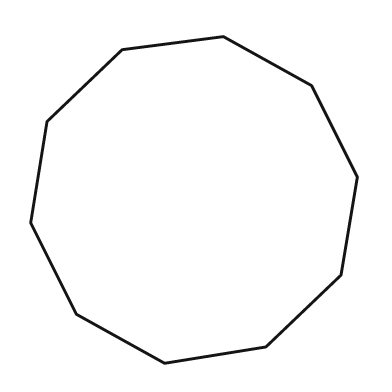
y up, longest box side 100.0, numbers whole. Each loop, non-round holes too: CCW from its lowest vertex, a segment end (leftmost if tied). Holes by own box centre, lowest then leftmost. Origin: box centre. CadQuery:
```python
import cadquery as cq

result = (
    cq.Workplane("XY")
    .moveTo(-9.0, -50.0)
    .lineTo(22.0, -45.0)
    .lineTo(45.0, -23.0)
    .lineTo(50.0, 7.0)
    .lineTo(36.0, 35.0)
    .lineTo(9.0, 50.0)
    .lineTo(-22.0, 46.0)
    .lineTo(-45.0, 24.0)
    .lineTo(-50.0, -7.0)
    .lineTo(-36.0, -35.0)
    .close()
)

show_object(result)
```